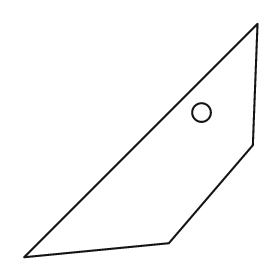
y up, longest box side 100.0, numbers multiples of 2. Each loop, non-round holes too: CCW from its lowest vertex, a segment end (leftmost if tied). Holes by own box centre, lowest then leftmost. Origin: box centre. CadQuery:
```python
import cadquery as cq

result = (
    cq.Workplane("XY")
    .moveTo(-50.0, -50.0)
    .lineTo(12.0, -44.0)
    .lineTo(48.0, -2.0)
    .lineTo(50.0, 50.0)
    .close()
    .moveTo(26.0, 12.0)
    .circle(4.0)
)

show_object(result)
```